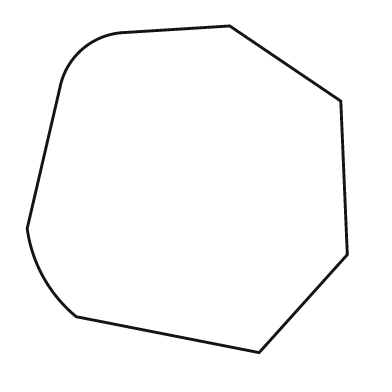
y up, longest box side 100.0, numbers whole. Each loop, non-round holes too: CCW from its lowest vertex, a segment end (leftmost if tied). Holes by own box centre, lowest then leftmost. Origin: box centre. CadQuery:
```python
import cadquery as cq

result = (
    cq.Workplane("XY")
    .moveTo(22.0, -50.0)
    .lineTo(49.0, -20.0)
    .lineTo(47.0, 27.0)
    .lineTo(13.0, 50.0)
    .lineTo(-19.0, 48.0)
    .threePointArc((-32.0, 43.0), (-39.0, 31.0))
    .lineTo(-49.0, -12.0)
    .threePointArc((-44.0, -27.0), (-34.0, -39.0))
    .close()
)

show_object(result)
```